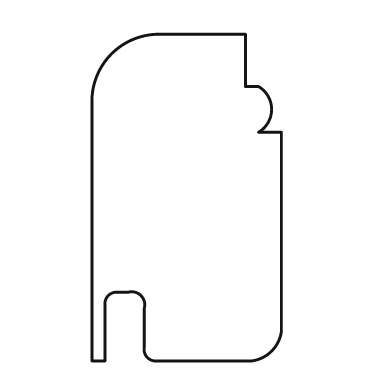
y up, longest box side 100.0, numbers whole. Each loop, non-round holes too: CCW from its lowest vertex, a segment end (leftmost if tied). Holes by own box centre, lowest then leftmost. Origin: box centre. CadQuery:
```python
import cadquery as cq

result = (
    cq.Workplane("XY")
    .moveTo(-29.0, -50.0)
    .lineTo(-25.0, -50.0)
    .lineTo(-25.0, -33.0)
    .threePointArc((-24.0, -30.0), (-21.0, -29.0))
    .lineTo(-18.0, -29.0)
    .threePointArc((-14.0, -30.0), (-13.0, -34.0))
    .lineTo(-13.0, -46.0)
    .threePointArc((-12.0, -49.0), (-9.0, -50.0))
    .lineTo(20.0, -50.0)
    .threePointArc((26.0, -47.0), (29.0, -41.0))
    .lineTo(29.0, 20.0)
    .lineTo(22.0, 20.0)
    .threePointArc((26.0, 27.0), (22.0, 34.0))
    .lineTo(18.0, 34.0)
    .lineTo(18.0, 50.0)
    .lineTo(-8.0, 50.0)
    .threePointArc((-23.0, 44.0), (-29.0, 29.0))
    .close()
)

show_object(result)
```